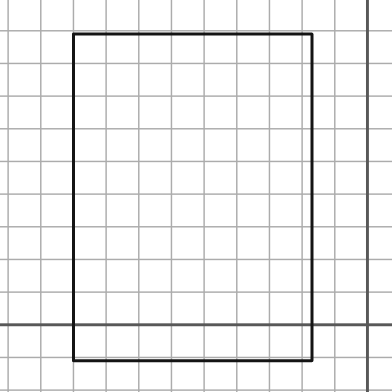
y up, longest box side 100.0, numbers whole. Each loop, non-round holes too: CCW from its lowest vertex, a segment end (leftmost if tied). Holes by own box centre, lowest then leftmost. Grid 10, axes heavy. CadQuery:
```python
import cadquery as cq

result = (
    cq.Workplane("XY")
    .moveTo(-90.0, -11.0)
    .lineTo(-17.0, -11.0)
    .lineTo(-17.0, 89.0)
    .lineTo(-90.0, 89.0)
    .close()
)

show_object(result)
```